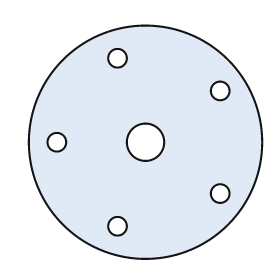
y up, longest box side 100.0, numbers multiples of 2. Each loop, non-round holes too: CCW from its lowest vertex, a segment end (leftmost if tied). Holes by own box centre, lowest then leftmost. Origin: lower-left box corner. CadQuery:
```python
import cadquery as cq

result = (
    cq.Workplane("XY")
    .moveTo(50.0, 50.0)
    .circle(50.0)
    .moveTo(38.0, 14.0)
    .circle(4.0)
    .moveTo(82.0, 28.0)
    .circle(4.0)
    .moveTo(12.0, 50.0)
    .circle(4.0)
    .moveTo(50.0, 50.0)
    .circle(8.0)
    .moveTo(82.0, 72.0)
    .circle(4.0)
    .moveTo(38.0, 86.0)
    .circle(4.0)
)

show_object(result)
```